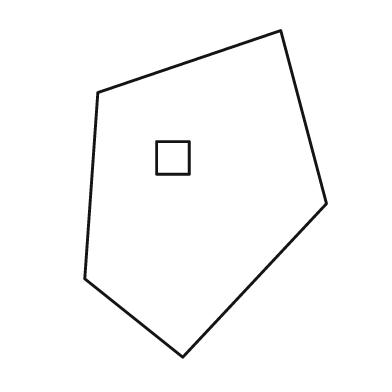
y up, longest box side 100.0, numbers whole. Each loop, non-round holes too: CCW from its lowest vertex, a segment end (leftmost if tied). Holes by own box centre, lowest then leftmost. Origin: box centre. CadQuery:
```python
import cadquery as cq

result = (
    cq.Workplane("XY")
    .moveTo(-7.0, -50.0)
    .lineTo(37.0, -3.0)
    .lineTo(23.0, 50.0)
    .lineTo(-33.0, 31.0)
    .lineTo(-37.0, -26.0)
    .close()
    .moveTo(-15.0, 6.0)
    .lineTo(-5.0, 6.0)
    .lineTo(-5.0, 16.0)
    .lineTo(-15.0, 16.0)
    .close()
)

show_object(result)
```